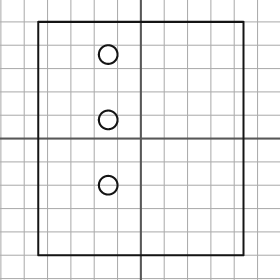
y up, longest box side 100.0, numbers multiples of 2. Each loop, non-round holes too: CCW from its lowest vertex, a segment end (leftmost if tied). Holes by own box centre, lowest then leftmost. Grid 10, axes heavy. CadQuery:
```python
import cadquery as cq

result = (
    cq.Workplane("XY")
    .moveTo(-44.0, -50.0)
    .lineTo(44.0, -50.0)
    .lineTo(44.0, 50.0)
    .lineTo(-44.0, 50.0)
    .close()
    .moveTo(-14.0, -20.0)
    .circle(4.0)
    .moveTo(-14.0, 8.0)
    .circle(4.0)
    .moveTo(-14.0, 36.0)
    .circle(4.0)
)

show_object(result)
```